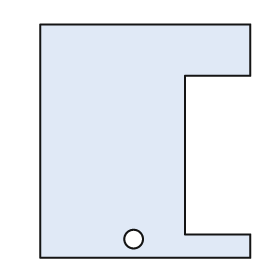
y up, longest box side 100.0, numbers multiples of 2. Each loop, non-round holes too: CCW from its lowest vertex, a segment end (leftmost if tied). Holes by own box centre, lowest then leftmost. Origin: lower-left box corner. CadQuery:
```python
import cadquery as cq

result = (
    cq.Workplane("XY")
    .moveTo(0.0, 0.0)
    .lineTo(90.0, 0.0)
    .lineTo(90.0, 10.0)
    .lineTo(62.0, 10.0)
    .lineTo(62.0, 78.0)
    .lineTo(90.0, 78.0)
    .lineTo(90.0, 100.0)
    .lineTo(0.0, 100.0)
    .close()
    .moveTo(40.0, 8.0)
    .circle(4.0)
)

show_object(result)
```